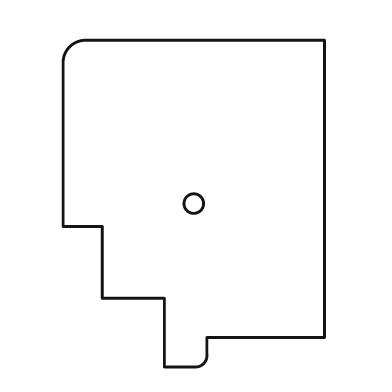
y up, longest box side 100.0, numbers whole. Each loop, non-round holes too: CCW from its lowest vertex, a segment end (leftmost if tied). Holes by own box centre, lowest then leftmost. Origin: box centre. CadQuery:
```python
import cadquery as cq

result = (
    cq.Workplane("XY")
    .moveTo(-9.0, -50.0)
    .lineTo(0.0, -50.0)
    .threePointArc((3.0, -49.0), (4.0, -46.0))
    .lineTo(4.0, -41.0)
    .lineTo(40.0, -41.0)
    .lineTo(40.0, 50.0)
    .lineTo(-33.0, 50.0)
    .threePointArc((-38.0, 48.0), (-40.0, 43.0))
    .lineTo(-40.0, -7.0)
    .lineTo(-28.0, -7.0)
    .lineTo(-28.0, -29.0)
    .lineTo(-9.0, -29.0)
    .close()
    .moveTo(0.0, 0.0)
    .circle(3.0)
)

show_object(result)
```